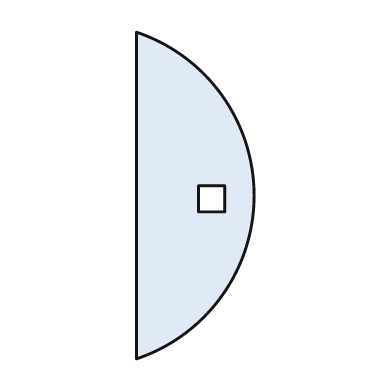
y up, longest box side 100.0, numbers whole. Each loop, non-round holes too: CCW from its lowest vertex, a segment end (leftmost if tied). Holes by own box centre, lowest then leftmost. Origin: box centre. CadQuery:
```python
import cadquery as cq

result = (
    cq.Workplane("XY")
    .moveTo(-18.0, -50.0)
    .threePointArc((18.0, 0.0), (-18.0, 50.0))
    .close()
    .moveTo(1.0, -5.0)
    .lineTo(9.0, -5.0)
    .lineTo(9.0, 3.0)
    .lineTo(1.0, 3.0)
    .close()
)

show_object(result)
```